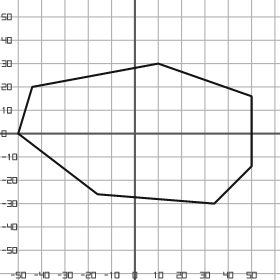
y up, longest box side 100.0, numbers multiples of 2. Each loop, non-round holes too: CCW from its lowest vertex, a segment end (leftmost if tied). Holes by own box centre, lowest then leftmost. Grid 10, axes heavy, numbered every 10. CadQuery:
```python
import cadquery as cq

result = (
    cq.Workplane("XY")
    .moveTo(34.0, -30.0)
    .lineTo(50.0, -14.0)
    .lineTo(50.0, 16.0)
    .lineTo(10.0, 30.0)
    .lineTo(-44.0, 20.0)
    .lineTo(-50.0, 0.0)
    .lineTo(-16.0, -26.0)
    .close()
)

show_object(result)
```